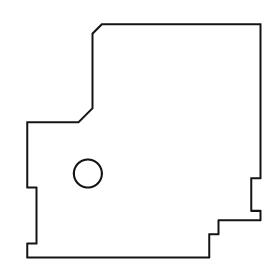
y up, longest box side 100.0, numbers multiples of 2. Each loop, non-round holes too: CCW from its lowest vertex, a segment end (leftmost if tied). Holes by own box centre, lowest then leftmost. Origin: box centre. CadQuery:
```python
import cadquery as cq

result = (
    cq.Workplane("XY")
    .moveTo(-50.0, -50.0)
    .lineTo(28.0, -50.0)
    .lineTo(28.0, -40.0)
    .lineTo(32.0, -40.0)
    .lineTo(32.0, -34.0)
    .lineTo(50.0, -34.0)
    .lineTo(50.0, -30.0)
    .lineTo(46.0, -30.0)
    .lineTo(46.0, -16.0)
    .lineTo(50.0, -16.0)
    .lineTo(50.0, 50.0)
    .lineTo(-18.0, 50.0)
    .lineTo(-22.0, 46.0)
    .lineTo(-22.0, 14.0)
    .lineTo(-28.0, 8.0)
    .lineTo(-50.0, 8.0)
    .lineTo(-50.0, -20.0)
    .lineTo(-46.0, -20.0)
    .lineTo(-46.0, -44.0)
    .lineTo(-50.0, -44.0)
    .close()
    .moveTo(-24.0, -14.0)
    .circle(6.0)
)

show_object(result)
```